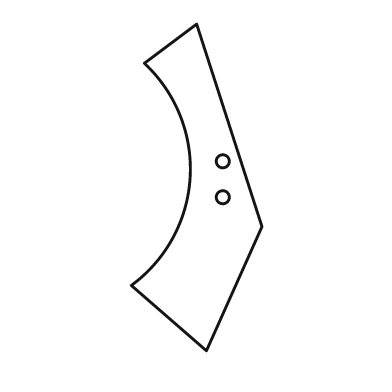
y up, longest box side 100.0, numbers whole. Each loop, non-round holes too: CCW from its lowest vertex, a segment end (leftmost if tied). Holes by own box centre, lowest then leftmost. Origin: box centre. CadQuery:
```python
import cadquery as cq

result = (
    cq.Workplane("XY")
    .moveTo(3.0, -50.0)
    .lineTo(20.0, -12.0)
    .lineTo(0.0, 50.0)
    .lineTo(-16.0, 38.0)
    .threePointArc((-2.0, 3.0), (-20.0, -30.0))
    .close()
    .moveTo(8.0, -3.0)
    .circle(2.0)
    .moveTo(8.0, 8.0)
    .circle(2.0)
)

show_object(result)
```